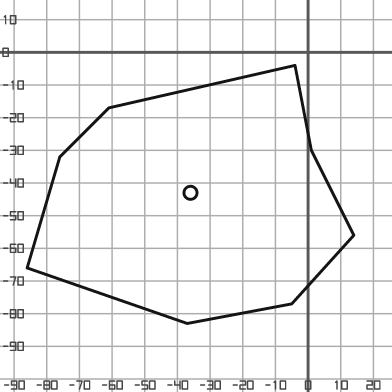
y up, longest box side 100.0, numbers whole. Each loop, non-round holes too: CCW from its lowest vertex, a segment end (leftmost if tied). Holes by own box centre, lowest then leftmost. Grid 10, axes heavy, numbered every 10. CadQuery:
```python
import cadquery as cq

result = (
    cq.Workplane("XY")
    .moveTo(-37.0, -83.0)
    .lineTo(-5.0, -77.0)
    .lineTo(14.0, -56.0)
    .lineTo(1.0, -30.0)
    .lineTo(-4.0, -4.0)
    .lineTo(-61.0, -17.0)
    .lineTo(-76.0, -32.0)
    .lineTo(-86.0, -66.0)
    .close()
    .moveTo(-36.0, -43.0)
    .circle(2.0)
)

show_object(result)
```